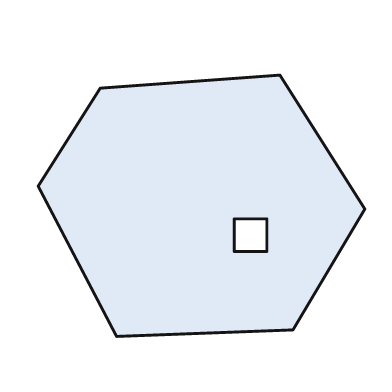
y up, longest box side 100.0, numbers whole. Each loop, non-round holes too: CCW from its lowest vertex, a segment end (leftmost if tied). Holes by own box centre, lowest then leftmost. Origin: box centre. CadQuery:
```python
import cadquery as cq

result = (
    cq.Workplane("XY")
    .moveTo(-26.0, -40.0)
    .lineTo(28.0, -38.0)
    .lineTo(50.0, -1.0)
    .lineTo(24.0, 40.0)
    .lineTo(-31.0, 36.0)
    .lineTo(-50.0, 6.0)
    .close()
    .moveTo(10.0, -14.0)
    .lineTo(20.0, -14.0)
    .lineTo(20.0, -4.0)
    .lineTo(10.0, -4.0)
    .close()
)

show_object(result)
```